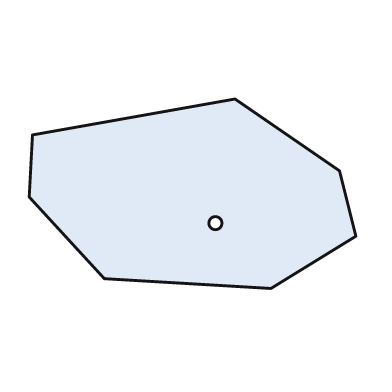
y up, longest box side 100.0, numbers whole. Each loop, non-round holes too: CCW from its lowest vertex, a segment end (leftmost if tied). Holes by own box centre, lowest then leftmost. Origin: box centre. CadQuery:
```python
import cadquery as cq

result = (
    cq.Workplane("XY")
    .moveTo(24.0, -29.0)
    .lineTo(50.0, -13.0)
    .lineTo(45.0, 7.0)
    .lineTo(13.0, 29.0)
    .lineTo(-49.0, 18.0)
    .lineTo(-50.0, -1.0)
    .lineTo(-27.0, -26.0)
    .close()
    .moveTo(7.0, -9.0)
    .circle(2.0)
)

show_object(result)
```